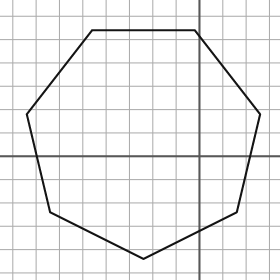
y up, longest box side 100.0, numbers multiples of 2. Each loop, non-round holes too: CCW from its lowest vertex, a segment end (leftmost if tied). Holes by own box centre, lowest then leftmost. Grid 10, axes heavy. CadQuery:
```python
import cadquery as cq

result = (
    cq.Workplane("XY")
    .moveTo(-24.0, -44.0)
    .lineTo(16.0, -24.0)
    .lineTo(26.0, 18.0)
    .lineTo(-2.0, 54.0)
    .lineTo(-46.0, 54.0)
    .lineTo(-74.0, 18.0)
    .lineTo(-64.0, -24.0)
    .close()
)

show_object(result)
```